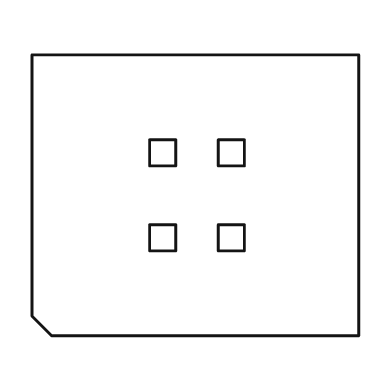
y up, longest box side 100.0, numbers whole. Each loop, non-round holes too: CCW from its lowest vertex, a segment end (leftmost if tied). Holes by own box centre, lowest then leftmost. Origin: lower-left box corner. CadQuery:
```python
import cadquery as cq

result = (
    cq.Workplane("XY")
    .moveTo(6.0, 0.0)
    .lineTo(100.0, 0.0)
    .lineTo(100.0, 86.0)
    .lineTo(0.0, 86.0)
    .lineTo(0.0, 6.0)
    .close()
    .moveTo(36.0, 26.0)
    .lineTo(44.0, 26.0)
    .lineTo(44.0, 34.0)
    .lineTo(36.0, 34.0)
    .close()
    .moveTo(57.0, 26.0)
    .lineTo(65.0, 26.0)
    .lineTo(65.0, 34.0)
    .lineTo(57.0, 34.0)
    .close()
    .moveTo(36.0, 52.0)
    .lineTo(44.0, 52.0)
    .lineTo(44.0, 60.0)
    .lineTo(36.0, 60.0)
    .close()
    .moveTo(57.0, 52.0)
    .lineTo(65.0, 52.0)
    .lineTo(65.0, 60.0)
    .lineTo(57.0, 60.0)
    .close()
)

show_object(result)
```